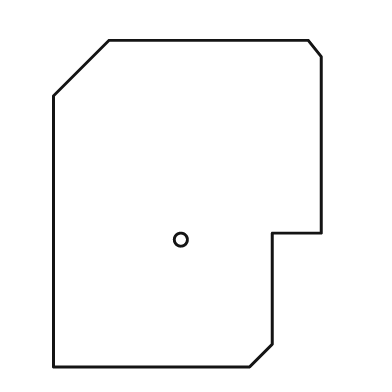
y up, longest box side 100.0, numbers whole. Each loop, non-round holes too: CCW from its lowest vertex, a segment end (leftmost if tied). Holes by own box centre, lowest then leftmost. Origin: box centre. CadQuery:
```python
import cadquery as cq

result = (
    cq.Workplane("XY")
    .moveTo(-41.0, -50.0)
    .lineTo(19.0, -50.0)
    .lineTo(26.0, -43.0)
    .lineTo(26.0, -9.0)
    .lineTo(41.0, -9.0)
    .lineTo(41.0, 45.0)
    .lineTo(37.0, 50.0)
    .lineTo(-24.0, 50.0)
    .lineTo(-41.0, 33.0)
    .close()
    .moveTo(-2.0, -11.0)
    .circle(2.0)
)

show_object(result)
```